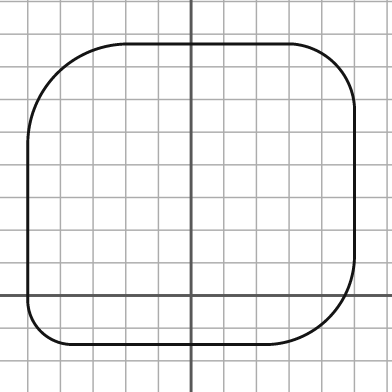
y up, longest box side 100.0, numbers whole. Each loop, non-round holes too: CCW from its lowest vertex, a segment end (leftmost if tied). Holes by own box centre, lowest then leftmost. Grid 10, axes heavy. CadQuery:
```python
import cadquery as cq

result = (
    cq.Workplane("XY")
    .moveTo(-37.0, -15.0)
    .lineTo(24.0, -15.0)
    .threePointArc((42.0, -7.0), (50.0, 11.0))
    .lineTo(50.0, 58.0)
    .threePointArc((44.0, 71.0), (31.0, 77.0))
    .lineTo(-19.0, 77.0)
    .threePointArc((-41.0, 68.0), (-50.0, 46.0))
    .lineTo(-50.0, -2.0)
    .threePointArc((-46.0, -11.0), (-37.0, -15.0))
    .close()
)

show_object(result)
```